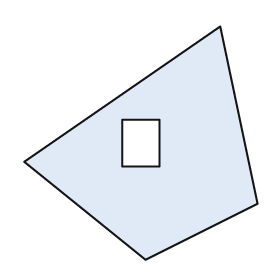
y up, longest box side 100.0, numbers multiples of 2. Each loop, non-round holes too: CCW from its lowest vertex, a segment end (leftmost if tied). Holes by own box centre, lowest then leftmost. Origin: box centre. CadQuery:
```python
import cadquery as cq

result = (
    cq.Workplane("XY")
    .moveTo(2.0, -50.0)
    .lineTo(50.0, -26.0)
    .lineTo(34.0, 50.0)
    .lineTo(-50.0, -8.0)
    .close()
    .moveTo(-8.0, -10.0)
    .lineTo(8.0, -10.0)
    .lineTo(8.0, 10.0)
    .lineTo(-8.0, 10.0)
    .close()
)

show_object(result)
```